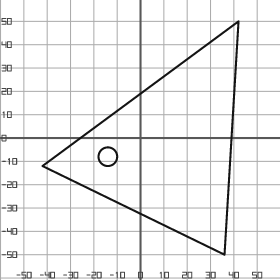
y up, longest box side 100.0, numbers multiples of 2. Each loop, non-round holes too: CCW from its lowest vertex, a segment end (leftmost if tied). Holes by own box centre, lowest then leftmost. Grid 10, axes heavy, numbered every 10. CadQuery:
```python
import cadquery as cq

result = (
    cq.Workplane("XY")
    .moveTo(36.0, -50.0)
    .lineTo(42.0, 50.0)
    .lineTo(-42.0, -12.0)
    .close()
    .moveTo(-14.0, -8.0)
    .circle(4.0)
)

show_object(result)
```